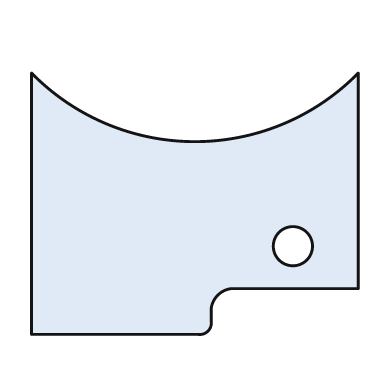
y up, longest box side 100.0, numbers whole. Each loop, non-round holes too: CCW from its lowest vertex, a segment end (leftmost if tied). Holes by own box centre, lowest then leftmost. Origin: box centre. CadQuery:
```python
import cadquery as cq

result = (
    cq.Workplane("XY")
    .moveTo(-50.0, -40.0)
    .lineTo(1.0, -40.0)
    .threePointArc((4.0, -39.0), (5.0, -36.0))
    .lineTo(5.0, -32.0)
    .threePointArc((7.0, -28.0), (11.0, -26.0))
    .lineTo(50.0, -26.0)
    .lineTo(50.0, 40.0)
    .threePointArc((0.0, 19.0), (-50.0, 40.0))
    .close()
    .moveTo(30.0, -13.0)
    .circle(6.0)
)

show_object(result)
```